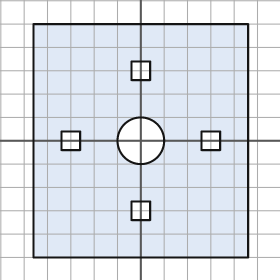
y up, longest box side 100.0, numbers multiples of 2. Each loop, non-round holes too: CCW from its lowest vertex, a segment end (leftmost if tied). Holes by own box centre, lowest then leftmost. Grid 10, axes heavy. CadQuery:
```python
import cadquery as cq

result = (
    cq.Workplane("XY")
    .moveTo(-46.0, -50.0)
    .lineTo(46.0, -50.0)
    .lineTo(46.0, 50.0)
    .lineTo(-46.0, 50.0)
    .close()
    .moveTo(-4.0, -34.0)
    .lineTo(4.0, -34.0)
    .lineTo(4.0, -26.0)
    .lineTo(-4.0, -26.0)
    .close()
    .moveTo(-34.0, -4.0)
    .lineTo(-26.0, -4.0)
    .lineTo(-26.0, 4.0)
    .lineTo(-34.0, 4.0)
    .close()
    .moveTo(0.0, 0.0)
    .circle(10.0)
    .moveTo(26.0, -4.0)
    .lineTo(34.0, -4.0)
    .lineTo(34.0, 4.0)
    .lineTo(26.0, 4.0)
    .close()
    .moveTo(-4.0, 26.0)
    .lineTo(4.0, 26.0)
    .lineTo(4.0, 34.0)
    .lineTo(-4.0, 34.0)
    .close()
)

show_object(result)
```